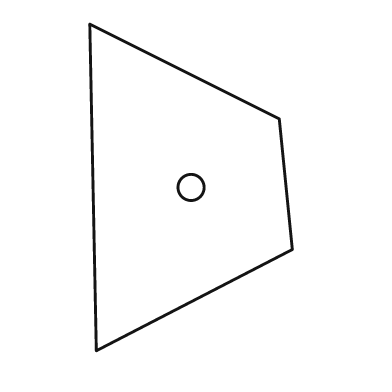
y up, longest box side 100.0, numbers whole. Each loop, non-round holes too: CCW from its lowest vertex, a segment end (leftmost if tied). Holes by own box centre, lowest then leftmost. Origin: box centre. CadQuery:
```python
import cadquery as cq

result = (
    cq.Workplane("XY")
    .moveTo(-29.0, -50.0)
    .lineTo(31.0, -19.0)
    .lineTo(27.0, 21.0)
    .lineTo(-31.0, 50.0)
    .close()
    .moveTo(0.0, 0.0)
    .circle(4.0)
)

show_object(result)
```